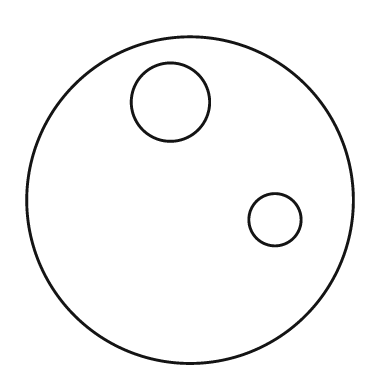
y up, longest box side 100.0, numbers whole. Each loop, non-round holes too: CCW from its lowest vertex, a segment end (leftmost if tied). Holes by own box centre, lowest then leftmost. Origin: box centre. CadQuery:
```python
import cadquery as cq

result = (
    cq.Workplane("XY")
    .moveTo(0.0, 0.0)
    .circle(50.0)
    .moveTo(26.0, -6.0)
    .circle(8.0)
    .moveTo(-6.0, 30.0)
    .circle(12.0)
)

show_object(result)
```